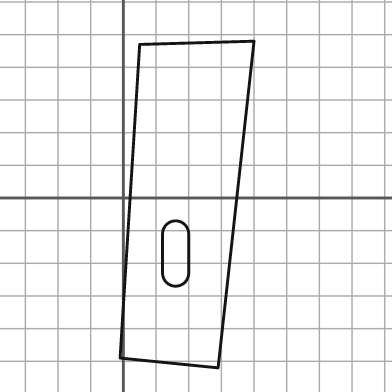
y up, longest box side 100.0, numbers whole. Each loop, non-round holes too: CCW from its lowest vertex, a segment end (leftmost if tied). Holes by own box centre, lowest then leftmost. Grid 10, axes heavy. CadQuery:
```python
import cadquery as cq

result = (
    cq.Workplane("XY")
    .moveTo(29.0, -52.0)
    .lineTo(40.0, 48.0)
    .lineTo(5.0, 47.0)
    .lineTo(-1.0, -49.0)
    .close()
    .moveTo(12.0, -23.0)
    .threePointArc((16.0, -27.0), (20.0, -23.0))
    .lineTo(20.0, -11.0)
    .threePointArc((16.0, -7.0), (12.0, -11.0))
    .close()
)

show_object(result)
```